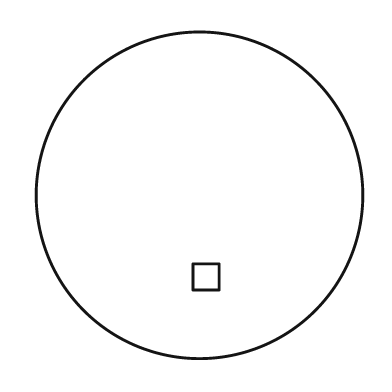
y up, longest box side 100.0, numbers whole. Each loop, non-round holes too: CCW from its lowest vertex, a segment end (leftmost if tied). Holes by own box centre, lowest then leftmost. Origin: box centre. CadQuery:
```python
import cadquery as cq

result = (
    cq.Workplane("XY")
    .moveTo(0.0, 0.0)
    .circle(50.0)
    .moveTo(-2.0, -29.0)
    .lineTo(6.0, -29.0)
    .lineTo(6.0, -21.0)
    .lineTo(-2.0, -21.0)
    .close()
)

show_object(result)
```